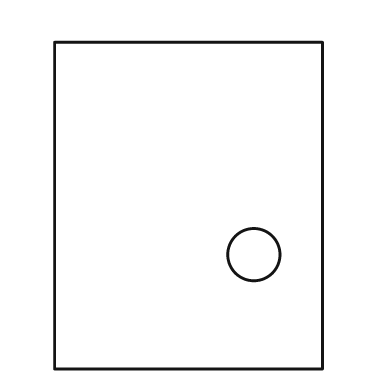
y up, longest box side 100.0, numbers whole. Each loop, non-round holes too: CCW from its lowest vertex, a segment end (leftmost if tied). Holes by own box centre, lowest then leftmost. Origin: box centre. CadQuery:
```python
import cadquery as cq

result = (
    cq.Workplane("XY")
    .moveTo(-41.0, -50.0)
    .lineTo(41.0, -50.0)
    .lineTo(41.0, 50.0)
    .lineTo(-41.0, 50.0)
    .close()
    .moveTo(20.0, -15.0)
    .circle(8.0)
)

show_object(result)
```